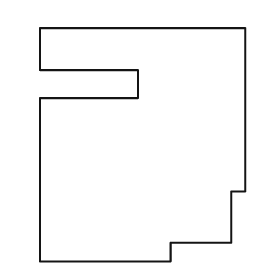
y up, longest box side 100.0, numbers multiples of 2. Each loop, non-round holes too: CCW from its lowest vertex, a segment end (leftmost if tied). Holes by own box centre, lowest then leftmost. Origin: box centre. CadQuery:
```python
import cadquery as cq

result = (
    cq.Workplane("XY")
    .moveTo(-44.0, -50.0)
    .lineTo(12.0, -50.0)
    .lineTo(12.0, -42.0)
    .lineTo(38.0, -42.0)
    .lineTo(38.0, -20.0)
    .lineTo(44.0, -20.0)
    .lineTo(44.0, 50.0)
    .lineTo(-44.0, 50.0)
    .lineTo(-44.0, 32.0)
    .lineTo(-2.0, 32.0)
    .lineTo(-2.0, 20.0)
    .lineTo(-44.0, 20.0)
    .close()
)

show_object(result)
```